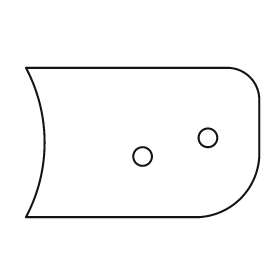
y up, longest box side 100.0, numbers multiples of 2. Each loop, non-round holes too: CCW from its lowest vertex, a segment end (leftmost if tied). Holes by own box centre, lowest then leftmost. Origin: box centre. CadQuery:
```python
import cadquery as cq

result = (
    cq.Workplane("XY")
    .moveTo(-50.0, -32.0)
    .lineTo(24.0, -32.0)
    .threePointArc((42.0, -24.0), (50.0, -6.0))
    .lineTo(50.0, 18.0)
    .threePointArc((46.0, 28.0), (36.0, 32.0))
    .lineTo(-50.0, 32.0)
    .threePointArc((-42.0, 0.0), (-50.0, -32.0))
    .close()
    .moveTo(0.0, -6.0)
    .circle(4.0)
    .moveTo(28.0, 2.0)
    .circle(4.0)
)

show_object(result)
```